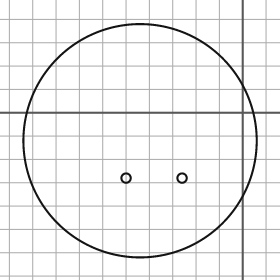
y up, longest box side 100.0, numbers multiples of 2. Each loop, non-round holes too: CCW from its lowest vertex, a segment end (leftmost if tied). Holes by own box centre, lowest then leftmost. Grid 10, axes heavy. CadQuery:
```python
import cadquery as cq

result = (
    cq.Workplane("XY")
    .moveTo(-44.0, -12.0)
    .circle(50.0)
    .moveTo(-50.0, -28.0)
    .circle(2.0)
    .moveTo(-26.0, -28.0)
    .circle(2.0)
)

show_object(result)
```